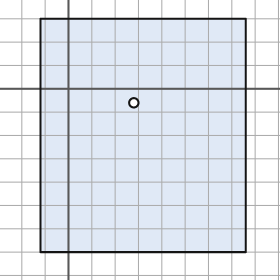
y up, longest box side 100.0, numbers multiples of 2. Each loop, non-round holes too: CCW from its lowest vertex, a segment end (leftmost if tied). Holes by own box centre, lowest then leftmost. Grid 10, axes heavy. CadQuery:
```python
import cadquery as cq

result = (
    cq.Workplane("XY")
    .moveTo(-12.0, -70.0)
    .lineTo(76.0, -70.0)
    .lineTo(76.0, 30.0)
    .lineTo(-12.0, 30.0)
    .close()
    .moveTo(28.0, -6.0)
    .circle(2.0)
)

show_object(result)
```